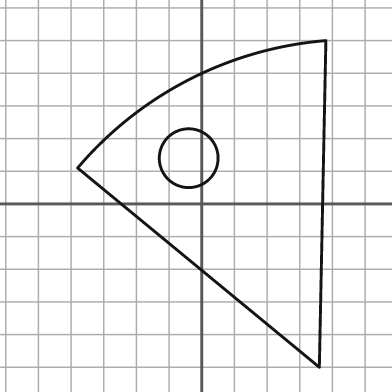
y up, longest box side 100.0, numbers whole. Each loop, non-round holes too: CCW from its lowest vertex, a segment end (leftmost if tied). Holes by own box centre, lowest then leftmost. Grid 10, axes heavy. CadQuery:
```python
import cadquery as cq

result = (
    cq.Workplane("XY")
    .moveTo(36.0, -50.0)
    .lineTo(38.0, 50.0)
    .threePointArc((-4.0, 38.0), (-38.0, 11.0))
    .close()
    .moveTo(-4.0, 14.0)
    .circle(9.0)
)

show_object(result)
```